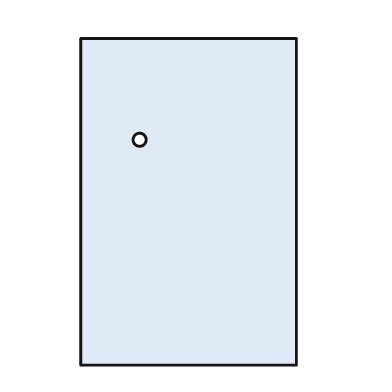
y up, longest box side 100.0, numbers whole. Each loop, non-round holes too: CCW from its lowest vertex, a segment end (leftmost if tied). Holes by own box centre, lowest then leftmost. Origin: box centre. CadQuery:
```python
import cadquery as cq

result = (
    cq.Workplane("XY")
    .moveTo(-33.0, -50.0)
    .lineTo(33.0, -50.0)
    .lineTo(33.0, 50.0)
    .lineTo(-33.0, 50.0)
    .close()
    .moveTo(-15.0, 19.0)
    .circle(2.0)
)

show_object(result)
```